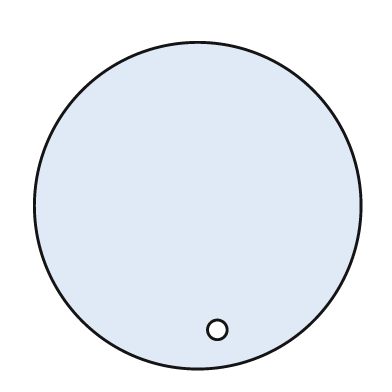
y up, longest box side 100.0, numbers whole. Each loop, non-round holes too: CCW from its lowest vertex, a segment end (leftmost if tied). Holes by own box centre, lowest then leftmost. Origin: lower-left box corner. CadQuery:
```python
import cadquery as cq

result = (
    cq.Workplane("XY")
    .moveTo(50.0, 50.0)
    .circle(50.0)
    .moveTo(56.0, 12.0)
    .circle(3.0)
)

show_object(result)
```